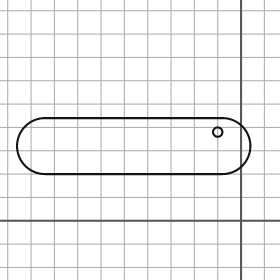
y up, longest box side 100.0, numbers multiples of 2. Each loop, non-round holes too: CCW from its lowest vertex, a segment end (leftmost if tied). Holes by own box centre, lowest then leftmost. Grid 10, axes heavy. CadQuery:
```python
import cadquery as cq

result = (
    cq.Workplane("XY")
    .moveTo(-84.0, 20.0)
    .lineTo(-8.0, 20.0)
    .threePointArc((4.0, 32.0), (-8.0, 44.0))
    .lineTo(-84.0, 44.0)
    .threePointArc((-96.0, 32.0), (-84.0, 20.0))
    .close()
    .moveTo(-10.0, 38.0)
    .circle(2.0)
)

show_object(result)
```